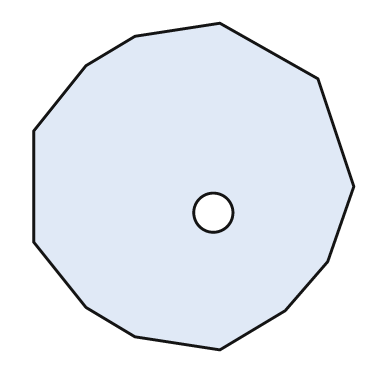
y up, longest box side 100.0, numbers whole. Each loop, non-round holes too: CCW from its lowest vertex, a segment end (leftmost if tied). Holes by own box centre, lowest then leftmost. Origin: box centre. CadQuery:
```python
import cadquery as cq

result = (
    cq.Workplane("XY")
    .moveTo(8.0, -50.0)
    .lineTo(28.0, -38.0)
    .lineTo(41.0, -23.0)
    .lineTo(49.0, 0.0)
    .lineTo(38.0, 33.0)
    .lineTo(8.0, 50.0)
    .lineTo(-18.0, 46.0)
    .lineTo(-33.0, 37.0)
    .lineTo(-49.0, 17.0)
    .lineTo(-49.0, -17.0)
    .lineTo(-33.0, -37.0)
    .lineTo(-18.0, -46.0)
    .close()
    .moveTo(6.0, -8.0)
    .circle(6.0)
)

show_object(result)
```